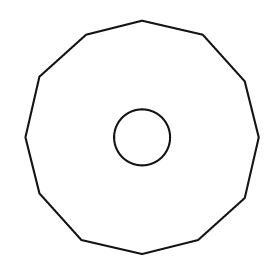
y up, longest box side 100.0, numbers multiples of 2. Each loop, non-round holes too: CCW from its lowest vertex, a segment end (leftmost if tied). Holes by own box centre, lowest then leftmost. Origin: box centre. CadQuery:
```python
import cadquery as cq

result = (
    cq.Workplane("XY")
    .moveTo(0.0, -50.0)
    .lineTo(24.0, -44.0)
    .lineTo(44.0, -26.0)
    .lineTo(50.0, 0.0)
    .lineTo(44.0, 24.0)
    .lineTo(26.0, 44.0)
    .lineTo(0.0, 50.0)
    .lineTo(-24.0, 44.0)
    .lineTo(-44.0, 26.0)
    .lineTo(-50.0, 0.0)
    .lineTo(-44.0, -24.0)
    .lineTo(-26.0, -44.0)
    .close()
    .moveTo(0.0, 0.0)
    .circle(12.0)
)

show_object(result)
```